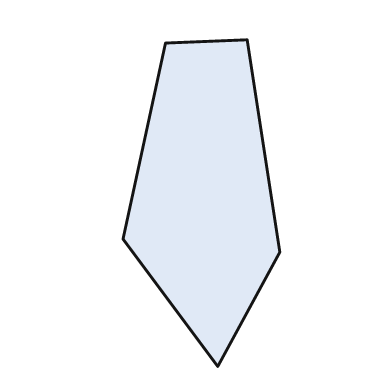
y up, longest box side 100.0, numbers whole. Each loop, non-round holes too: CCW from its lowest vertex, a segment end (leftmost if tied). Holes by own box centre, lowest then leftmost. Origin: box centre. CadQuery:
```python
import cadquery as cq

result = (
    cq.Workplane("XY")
    .moveTo(5.0, -50.0)
    .lineTo(24.0, -15.0)
    .lineTo(14.0, 50.0)
    .lineTo(-11.0, 49.0)
    .lineTo(-24.0, -11.0)
    .close()
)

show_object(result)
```